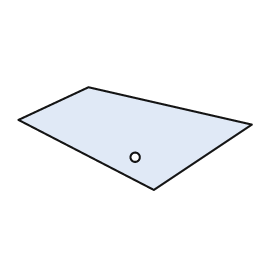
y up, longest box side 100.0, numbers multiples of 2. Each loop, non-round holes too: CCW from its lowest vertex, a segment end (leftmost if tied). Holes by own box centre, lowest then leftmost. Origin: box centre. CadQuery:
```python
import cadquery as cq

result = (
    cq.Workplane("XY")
    .moveTo(8.0, -22.0)
    .lineTo(50.0, 6.0)
    .lineTo(-20.0, 22.0)
    .lineTo(-50.0, 8.0)
    .close()
    .moveTo(0.0, -8.0)
    .circle(2.0)
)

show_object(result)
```